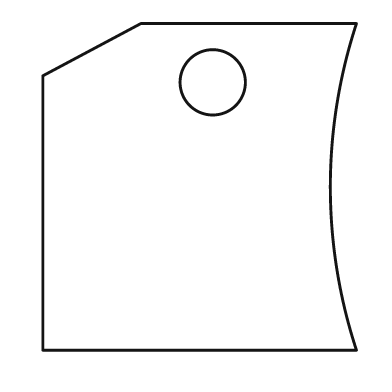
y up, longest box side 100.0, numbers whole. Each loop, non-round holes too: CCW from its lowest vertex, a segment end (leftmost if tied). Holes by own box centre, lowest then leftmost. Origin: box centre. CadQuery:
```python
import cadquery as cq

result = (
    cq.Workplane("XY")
    .moveTo(-48.0, -50.0)
    .lineTo(48.0, -50.0)
    .threePointArc((40.0, 0.0), (48.0, 50.0))
    .lineTo(-18.0, 50.0)
    .lineTo(-48.0, 34.0)
    .close()
    .moveTo(4.0, 32.0)
    .circle(10.0)
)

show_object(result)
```